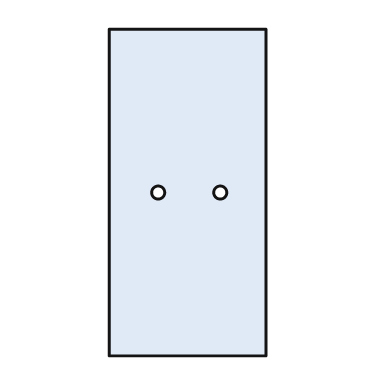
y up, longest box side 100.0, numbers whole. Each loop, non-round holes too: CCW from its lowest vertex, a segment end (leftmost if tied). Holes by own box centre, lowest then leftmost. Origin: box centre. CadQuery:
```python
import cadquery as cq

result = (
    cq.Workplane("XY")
    .moveTo(-24.0, -50.0)
    .lineTo(24.0, -50.0)
    .lineTo(24.0, 50.0)
    .lineTo(-24.0, 50.0)
    .close()
    .moveTo(-9.0, 0.0)
    .circle(2.0)
    .moveTo(10.0, 0.0)
    .circle(2.0)
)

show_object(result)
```